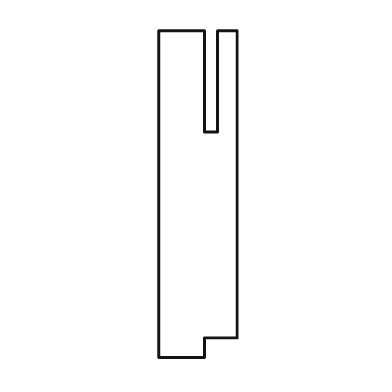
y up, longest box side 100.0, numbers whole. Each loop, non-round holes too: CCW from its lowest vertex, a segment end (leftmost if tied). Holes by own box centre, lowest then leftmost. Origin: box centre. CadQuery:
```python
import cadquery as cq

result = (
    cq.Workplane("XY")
    .moveTo(-12.0, -50.0)
    .lineTo(2.0, -50.0)
    .lineTo(2.0, -44.0)
    .lineTo(12.0, -44.0)
    .lineTo(12.0, 50.0)
    .lineTo(6.0, 50.0)
    .lineTo(6.0, 19.0)
    .lineTo(2.0, 19.0)
    .lineTo(2.0, 50.0)
    .lineTo(-12.0, 50.0)
    .close()
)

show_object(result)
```